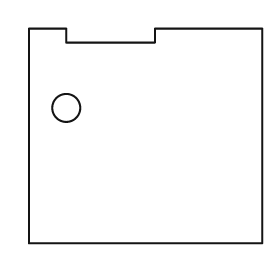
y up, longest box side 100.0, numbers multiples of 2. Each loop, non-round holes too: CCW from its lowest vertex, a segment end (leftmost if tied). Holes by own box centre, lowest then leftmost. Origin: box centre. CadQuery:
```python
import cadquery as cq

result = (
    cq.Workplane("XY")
    .moveTo(-50.0, -46.0)
    .lineTo(50.0, -46.0)
    .lineTo(50.0, 46.0)
    .lineTo(4.0, 46.0)
    .lineTo(4.0, 40.0)
    .lineTo(-34.0, 40.0)
    .lineTo(-34.0, 46.0)
    .lineTo(-50.0, 46.0)
    .close()
    .moveTo(-34.0, 12.0)
    .circle(6.0)
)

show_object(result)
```